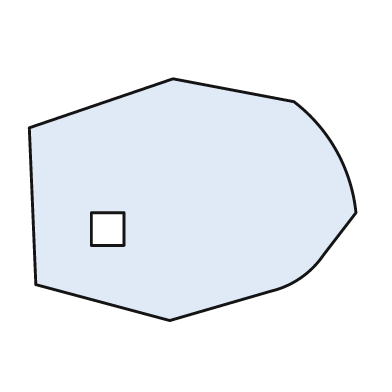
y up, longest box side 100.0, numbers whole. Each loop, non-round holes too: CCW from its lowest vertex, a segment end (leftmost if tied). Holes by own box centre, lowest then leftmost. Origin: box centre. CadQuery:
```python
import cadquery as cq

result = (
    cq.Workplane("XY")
    .moveTo(-7.0, -37.0)
    .lineTo(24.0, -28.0)
    .threePointArc((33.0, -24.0), (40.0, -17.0))
    .lineTo(50.0, -4.0)
    .threePointArc((44.0, 15.0), (31.0, 30.0))
    .lineTo(-6.0, 37.0)
    .lineTo(-50.0, 22.0)
    .lineTo(-48.0, -26.0)
    .close()
    .moveTo(-31.0, -14.0)
    .lineTo(-21.0, -14.0)
    .lineTo(-21.0, -4.0)
    .lineTo(-31.0, -4.0)
    .close()
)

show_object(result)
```